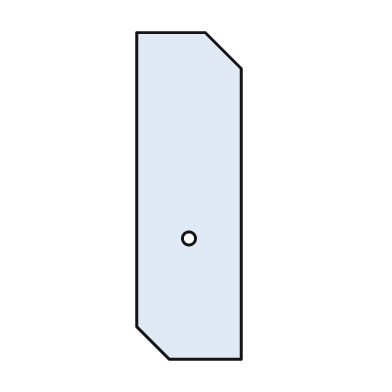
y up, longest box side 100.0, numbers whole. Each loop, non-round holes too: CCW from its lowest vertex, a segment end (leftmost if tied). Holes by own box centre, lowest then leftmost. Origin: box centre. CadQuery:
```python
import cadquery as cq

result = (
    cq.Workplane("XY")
    .moveTo(-6.0, -50.0)
    .lineTo(16.0, -50.0)
    .lineTo(16.0, 39.0)
    .lineTo(5.0, 50.0)
    .lineTo(-16.0, 50.0)
    .lineTo(-16.0, -40.0)
    .close()
    .moveTo(0.0, -13.0)
    .circle(2.0)
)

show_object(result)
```